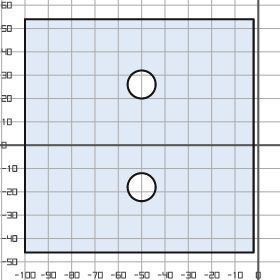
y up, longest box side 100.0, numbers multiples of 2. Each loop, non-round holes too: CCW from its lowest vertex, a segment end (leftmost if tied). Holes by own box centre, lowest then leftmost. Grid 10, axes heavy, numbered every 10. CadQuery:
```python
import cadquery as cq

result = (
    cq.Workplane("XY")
    .moveTo(-100.0, -46.0)
    .lineTo(-2.0, -46.0)
    .lineTo(-2.0, 54.0)
    .lineTo(-100.0, 54.0)
    .close()
    .moveTo(-50.0, -18.0)
    .circle(6.0)
    .moveTo(-50.0, 26.0)
    .circle(6.0)
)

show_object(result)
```